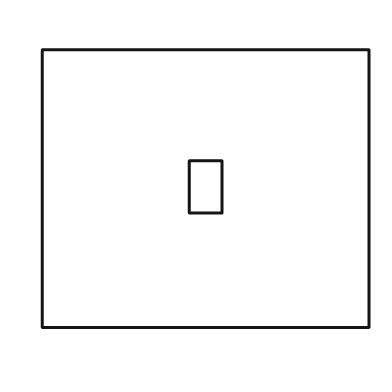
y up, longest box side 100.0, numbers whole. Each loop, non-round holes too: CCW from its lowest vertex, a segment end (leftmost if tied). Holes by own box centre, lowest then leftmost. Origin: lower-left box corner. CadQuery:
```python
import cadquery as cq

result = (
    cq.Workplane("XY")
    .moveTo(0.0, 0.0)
    .lineTo(100.0, 0.0)
    .lineTo(100.0, 85.0)
    .lineTo(0.0, 85.0)
    .close()
    .moveTo(45.0, 35.0)
    .lineTo(55.0, 35.0)
    .lineTo(55.0, 51.0)
    .lineTo(45.0, 51.0)
    .close()
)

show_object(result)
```